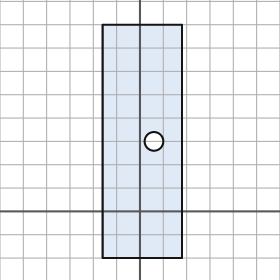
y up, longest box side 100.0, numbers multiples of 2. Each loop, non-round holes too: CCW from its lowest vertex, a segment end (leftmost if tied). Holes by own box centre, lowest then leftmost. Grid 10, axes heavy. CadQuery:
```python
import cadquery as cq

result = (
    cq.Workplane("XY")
    .moveTo(-16.0, -20.0)
    .lineTo(18.0, -20.0)
    .lineTo(18.0, 80.0)
    .lineTo(-16.0, 80.0)
    .close()
    .moveTo(6.0, 30.0)
    .circle(4.0)
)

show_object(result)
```